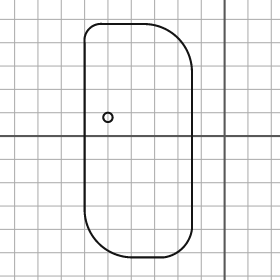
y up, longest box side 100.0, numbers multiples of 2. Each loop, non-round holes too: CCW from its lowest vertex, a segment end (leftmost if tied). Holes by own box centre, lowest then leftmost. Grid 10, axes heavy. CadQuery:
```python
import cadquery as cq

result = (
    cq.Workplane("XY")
    .moveTo(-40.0, -52.0)
    .lineTo(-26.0, -52.0)
    .threePointArc((-18.0, -48.0), (-14.0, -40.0))
    .lineTo(-14.0, 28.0)
    .threePointArc((-20.0, 42.0), (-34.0, 48.0))
    .lineTo(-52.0, 48.0)
    .threePointArc((-58.0, 46.0), (-60.0, 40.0))
    .lineTo(-60.0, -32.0)
    .threePointArc((-54.0, -46.0), (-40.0, -52.0))
    .close()
    .moveTo(-50.0, 8.0)
    .circle(2.0)
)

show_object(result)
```